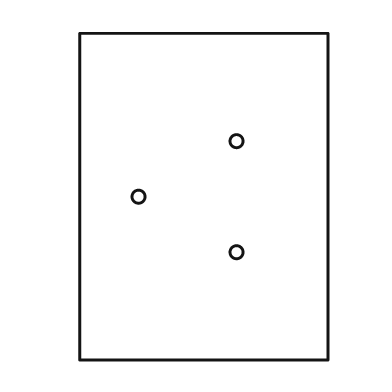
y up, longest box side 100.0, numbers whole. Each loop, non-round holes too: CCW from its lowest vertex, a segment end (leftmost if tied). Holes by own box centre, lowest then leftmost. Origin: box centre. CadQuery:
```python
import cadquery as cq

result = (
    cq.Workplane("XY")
    .moveTo(-38.0, -50.0)
    .lineTo(38.0, -50.0)
    .lineTo(38.0, 50.0)
    .lineTo(-38.0, 50.0)
    .close()
    .moveTo(10.0, -17.0)
    .circle(2.0)
    .moveTo(-20.0, 0.0)
    .circle(2.0)
    .moveTo(10.0, 17.0)
    .circle(2.0)
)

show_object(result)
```